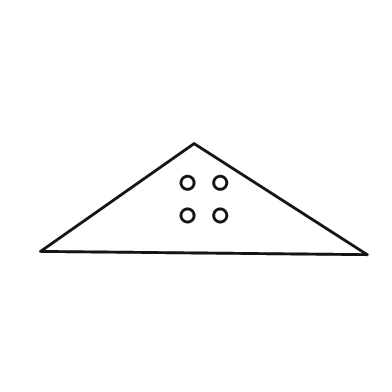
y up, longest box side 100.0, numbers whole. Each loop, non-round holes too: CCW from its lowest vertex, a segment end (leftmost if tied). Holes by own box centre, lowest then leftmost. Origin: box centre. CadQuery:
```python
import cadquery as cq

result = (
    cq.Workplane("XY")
    .moveTo(50.0, -17.0)
    .lineTo(-3.0, 17.0)
    .lineTo(-50.0, -16.0)
    .close()
    .moveTo(-5.0, -5.0)
    .circle(2.0)
    .moveTo(5.0, -5.0)
    .circle(2.0)
    .moveTo(-5.0, 5.0)
    .circle(2.0)
    .moveTo(5.0, 5.0)
    .circle(2.0)
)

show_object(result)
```